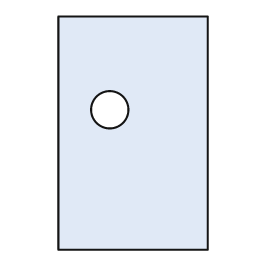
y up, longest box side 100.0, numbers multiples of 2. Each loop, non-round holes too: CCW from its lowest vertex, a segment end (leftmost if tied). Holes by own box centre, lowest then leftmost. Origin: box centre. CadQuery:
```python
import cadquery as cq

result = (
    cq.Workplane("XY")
    .moveTo(-32.0, -50.0)
    .lineTo(32.0, -50.0)
    .lineTo(32.0, 50.0)
    .lineTo(-32.0, 50.0)
    .close()
    .moveTo(-10.0, 10.0)
    .circle(8.0)
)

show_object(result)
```